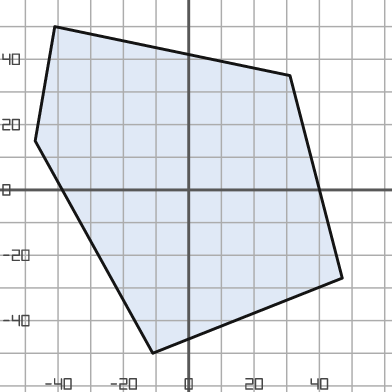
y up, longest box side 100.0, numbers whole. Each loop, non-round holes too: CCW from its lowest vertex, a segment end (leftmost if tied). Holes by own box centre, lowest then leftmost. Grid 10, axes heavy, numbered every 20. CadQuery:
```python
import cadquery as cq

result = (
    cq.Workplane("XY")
    .moveTo(-11.0, -50.0)
    .lineTo(47.0, -27.0)
    .lineTo(31.0, 35.0)
    .lineTo(-41.0, 50.0)
    .lineTo(-47.0, 15.0)
    .close()
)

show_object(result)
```